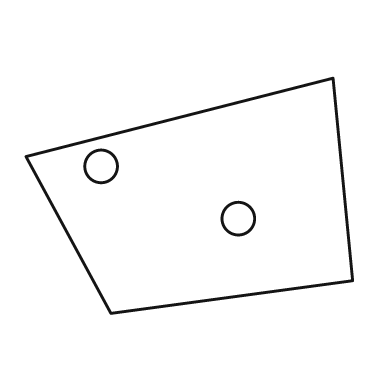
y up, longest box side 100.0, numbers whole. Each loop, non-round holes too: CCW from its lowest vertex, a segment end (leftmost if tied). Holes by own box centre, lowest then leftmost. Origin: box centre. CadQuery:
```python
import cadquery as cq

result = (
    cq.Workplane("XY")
    .moveTo(-24.0, -36.0)
    .lineTo(50.0, -26.0)
    .lineTo(44.0, 36.0)
    .lineTo(-50.0, 12.0)
    .close()
    .moveTo(15.0, -7.0)
    .circle(5.0)
    .moveTo(-27.0, 9.0)
    .circle(5.0)
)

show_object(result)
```